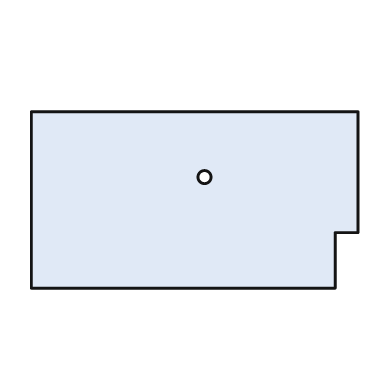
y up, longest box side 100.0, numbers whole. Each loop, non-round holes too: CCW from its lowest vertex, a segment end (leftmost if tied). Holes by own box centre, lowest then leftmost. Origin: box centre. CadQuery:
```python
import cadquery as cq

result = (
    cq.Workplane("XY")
    .moveTo(-50.0, -27.0)
    .lineTo(43.0, -27.0)
    .lineTo(43.0, -10.0)
    .lineTo(50.0, -10.0)
    .lineTo(50.0, 27.0)
    .lineTo(-50.0, 27.0)
    .close()
    .moveTo(3.0, 7.0)
    .circle(2.0)
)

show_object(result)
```